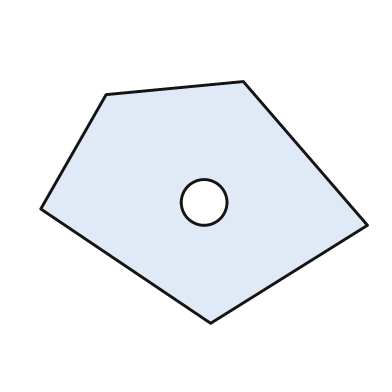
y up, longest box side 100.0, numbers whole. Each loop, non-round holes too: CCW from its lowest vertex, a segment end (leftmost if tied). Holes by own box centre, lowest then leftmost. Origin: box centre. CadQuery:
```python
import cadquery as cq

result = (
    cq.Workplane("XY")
    .moveTo(2.0, -37.0)
    .lineTo(50.0, -7.0)
    .lineTo(12.0, 37.0)
    .lineTo(-30.0, 33.0)
    .lineTo(-50.0, -2.0)
    .close()
    .moveTo(0.0, 0.0)
    .circle(7.0)
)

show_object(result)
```